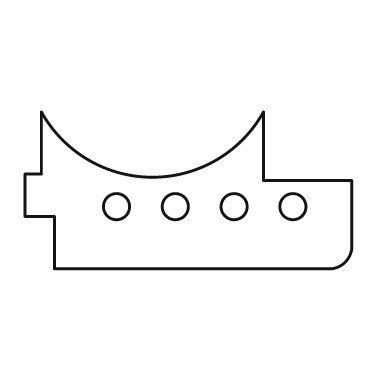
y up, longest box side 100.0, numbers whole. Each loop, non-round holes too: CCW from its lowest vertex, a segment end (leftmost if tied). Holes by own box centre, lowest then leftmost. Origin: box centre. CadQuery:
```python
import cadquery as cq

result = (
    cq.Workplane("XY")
    .moveTo(-41.0, -24.0)
    .lineTo(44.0, -24.0)
    .threePointArc((48.0, -22.0), (50.0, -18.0))
    .lineTo(50.0, 3.0)
    .lineTo(23.0, 3.0)
    .lineTo(23.0, 24.0)
    .threePointArc((-11.0, 4.0), (-45.0, 24.0))
    .lineTo(-45.0, 5.0)
    .lineTo(-50.0, 5.0)
    .lineTo(-50.0, -8.0)
    .lineTo(-41.0, -8.0)
    .close()
    .moveTo(-22.0, -5.0)
    .circle(4.0)
    .moveTo(-4.0, -5.0)
    .circle(4.0)
    .moveTo(14.0, -5.0)
    .circle(4.0)
    .moveTo(32.0, -5.0)
    .circle(4.0)
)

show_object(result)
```